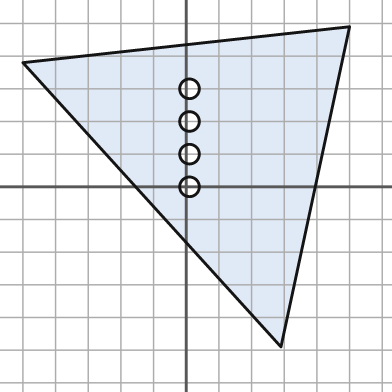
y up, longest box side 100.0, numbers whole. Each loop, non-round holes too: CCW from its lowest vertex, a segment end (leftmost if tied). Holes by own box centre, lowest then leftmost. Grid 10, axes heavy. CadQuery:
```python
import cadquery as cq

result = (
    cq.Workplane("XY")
    .moveTo(29.0, -49.0)
    .lineTo(50.0, 49.0)
    .lineTo(-50.0, 38.0)
    .close()
    .moveTo(1.0, 0.0)
    .circle(3.0)
    .moveTo(1.0, 10.0)
    .circle(3.0)
    .moveTo(1.0, 20.0)
    .circle(3.0)
    .moveTo(1.0, 30.0)
    .circle(3.0)
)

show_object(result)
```